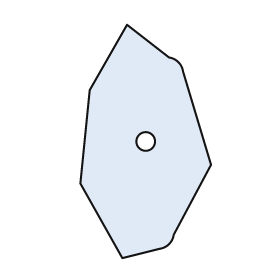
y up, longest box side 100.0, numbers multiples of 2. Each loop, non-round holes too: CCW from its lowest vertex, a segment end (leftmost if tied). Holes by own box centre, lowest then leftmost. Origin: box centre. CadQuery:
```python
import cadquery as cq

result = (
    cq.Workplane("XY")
    .moveTo(-10.0, -50.0)
    .lineTo(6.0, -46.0)
    .threePointArc((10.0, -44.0), (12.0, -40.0))
    .lineTo(28.0, -10.0)
    .lineTo(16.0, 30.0)
    .threePointArc((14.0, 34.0), (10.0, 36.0))
    .lineTo(-8.0, 50.0)
    .lineTo(-24.0, 22.0)
    .lineTo(-28.0, -18.0)
    .close()
    .moveTo(0.0, 0.0)
    .circle(4.0)
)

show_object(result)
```